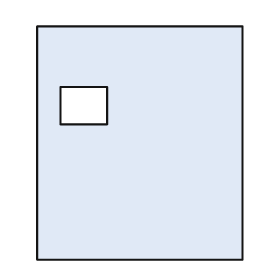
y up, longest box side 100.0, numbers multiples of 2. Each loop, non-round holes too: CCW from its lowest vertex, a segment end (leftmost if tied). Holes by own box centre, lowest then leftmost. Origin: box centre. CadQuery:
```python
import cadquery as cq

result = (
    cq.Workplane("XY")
    .moveTo(-44.0, -50.0)
    .lineTo(44.0, -50.0)
    .lineTo(44.0, 50.0)
    .lineTo(-44.0, 50.0)
    .close()
    .moveTo(-34.0, 8.0)
    .lineTo(-14.0, 8.0)
    .lineTo(-14.0, 24.0)
    .lineTo(-34.0, 24.0)
    .close()
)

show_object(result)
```